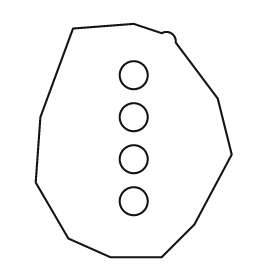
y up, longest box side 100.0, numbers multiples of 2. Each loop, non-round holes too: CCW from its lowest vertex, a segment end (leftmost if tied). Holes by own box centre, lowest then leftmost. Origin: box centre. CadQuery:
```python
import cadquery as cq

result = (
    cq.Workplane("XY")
    .moveTo(-10.0, -50.0)
    .lineTo(12.0, -50.0)
    .lineTo(26.0, -36.0)
    .lineTo(42.0, -6.0)
    .lineTo(36.0, 18.0)
    .lineTo(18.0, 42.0)
    .threePointArc((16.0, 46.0), (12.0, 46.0))
    .lineTo(0.0, 50.0)
    .lineTo(-26.0, 48.0)
    .lineTo(-40.0, 10.0)
    .lineTo(-42.0, -18.0)
    .lineTo(-28.0, -42.0)
    .close()
    .moveTo(0.0, -26.0)
    .circle(6.0)
    .moveTo(0.0, -8.0)
    .circle(6.0)
    .moveTo(0.0, 10.0)
    .circle(6.0)
    .moveTo(0.0, 28.0)
    .circle(6.0)
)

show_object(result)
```